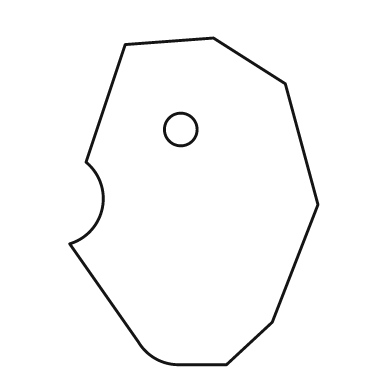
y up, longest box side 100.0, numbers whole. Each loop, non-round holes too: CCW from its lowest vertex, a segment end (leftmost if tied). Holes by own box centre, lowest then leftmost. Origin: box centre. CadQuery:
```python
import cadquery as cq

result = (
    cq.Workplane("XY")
    .moveTo(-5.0, -50.0)
    .lineTo(10.0, -50.0)
    .lineTo(24.0, -37.0)
    .lineTo(38.0, -1.0)
    .lineTo(28.0, 36.0)
    .lineTo(6.0, 50.0)
    .lineTo(-21.0, 48.0)
    .lineTo(-33.0, 12.0)
    .threePointArc((-28.0, -2.0), (-38.0, -13.0))
    .lineTo(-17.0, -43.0)
    .threePointArc((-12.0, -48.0), (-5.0, -50.0))
    .close()
    .moveTo(-4.0, 22.0)
    .circle(5.0)
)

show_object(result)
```